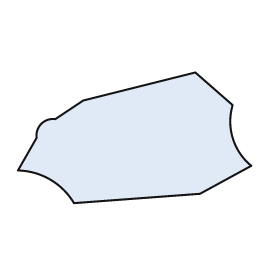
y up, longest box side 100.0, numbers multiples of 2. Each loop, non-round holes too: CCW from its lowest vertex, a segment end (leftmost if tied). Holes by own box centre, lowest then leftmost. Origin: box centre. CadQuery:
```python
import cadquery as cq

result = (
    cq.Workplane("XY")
    .moveTo(-26.0, -28.0)
    .lineTo(28.0, -24.0)
    .lineTo(50.0, -12.0)
    .threePointArc((42.0, 0.0), (42.0, 14.0))
    .lineTo(26.0, 28.0)
    .lineTo(-22.0, 16.0)
    .lineTo(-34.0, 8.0)
    .threePointArc((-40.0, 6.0), (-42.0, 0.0))
    .lineTo(-50.0, -14.0)
    .threePointArc((-36.0, -18.0), (-26.0, -28.0))
    .close()
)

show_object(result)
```